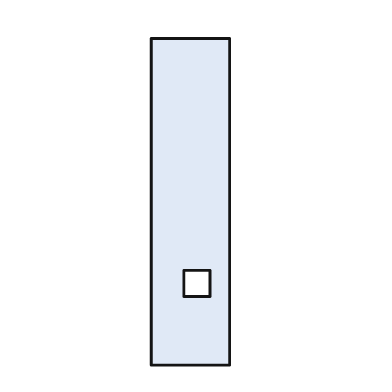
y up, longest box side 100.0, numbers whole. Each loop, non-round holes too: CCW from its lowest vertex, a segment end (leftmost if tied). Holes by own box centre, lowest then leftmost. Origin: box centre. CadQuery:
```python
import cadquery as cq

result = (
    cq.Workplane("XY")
    .moveTo(-12.0, -50.0)
    .lineTo(12.0, -50.0)
    .lineTo(12.0, 50.0)
    .lineTo(-12.0, 50.0)
    .close()
    .moveTo(-2.0, -29.0)
    .lineTo(6.0, -29.0)
    .lineTo(6.0, -21.0)
    .lineTo(-2.0, -21.0)
    .close()
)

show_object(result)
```